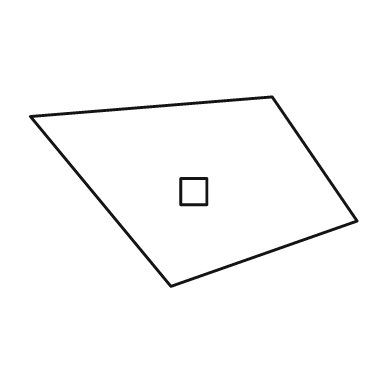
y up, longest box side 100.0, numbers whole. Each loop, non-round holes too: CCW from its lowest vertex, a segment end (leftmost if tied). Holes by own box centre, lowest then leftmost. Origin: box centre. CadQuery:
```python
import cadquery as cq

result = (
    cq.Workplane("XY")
    .moveTo(-7.0, -29.0)
    .lineTo(50.0, -9.0)
    .lineTo(24.0, 29.0)
    .lineTo(-50.0, 23.0)
    .close()
    .moveTo(-4.0, -4.0)
    .lineTo(4.0, -4.0)
    .lineTo(4.0, 4.0)
    .lineTo(-4.0, 4.0)
    .close()
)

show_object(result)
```